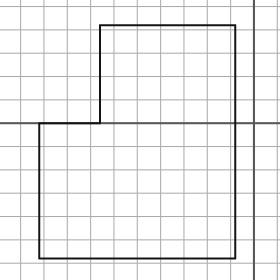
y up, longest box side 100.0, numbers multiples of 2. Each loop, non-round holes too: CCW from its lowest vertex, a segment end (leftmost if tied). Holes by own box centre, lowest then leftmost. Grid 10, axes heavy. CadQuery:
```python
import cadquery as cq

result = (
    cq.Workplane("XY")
    .moveTo(-92.0, -58.0)
    .lineTo(-8.0, -58.0)
    .lineTo(-8.0, 42.0)
    .lineTo(-66.0, 42.0)
    .lineTo(-66.0, 0.0)
    .lineTo(-92.0, 0.0)
    .close()
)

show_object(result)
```